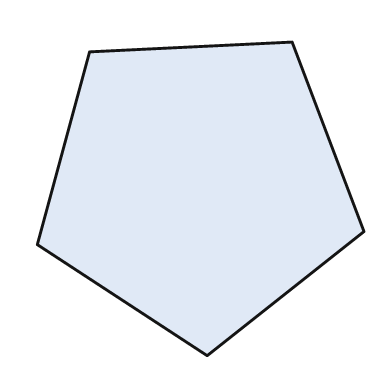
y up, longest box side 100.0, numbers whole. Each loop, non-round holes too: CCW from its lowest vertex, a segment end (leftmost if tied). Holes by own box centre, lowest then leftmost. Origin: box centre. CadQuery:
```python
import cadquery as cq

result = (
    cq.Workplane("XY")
    .moveTo(2.0, -48.0)
    .lineTo(50.0, -10.0)
    .lineTo(28.0, 48.0)
    .lineTo(-34.0, 45.0)
    .lineTo(-50.0, -14.0)
    .close()
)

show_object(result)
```